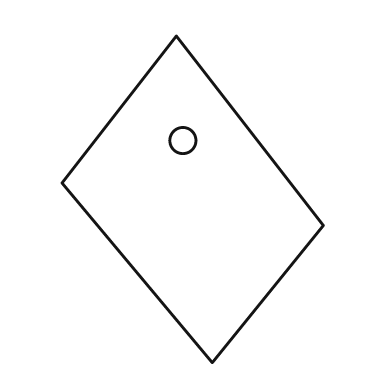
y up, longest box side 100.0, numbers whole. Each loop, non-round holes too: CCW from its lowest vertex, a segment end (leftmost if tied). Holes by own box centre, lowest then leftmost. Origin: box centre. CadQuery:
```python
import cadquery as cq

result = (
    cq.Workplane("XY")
    .moveTo(6.0, -50.0)
    .lineTo(40.0, -8.0)
    .lineTo(-5.0, 50.0)
    .lineTo(-40.0, 5.0)
    .close()
    .moveTo(-3.0, 18.0)
    .circle(4.0)
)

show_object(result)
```